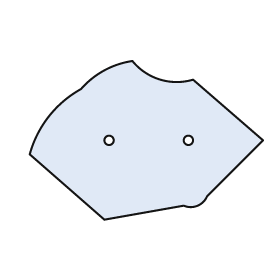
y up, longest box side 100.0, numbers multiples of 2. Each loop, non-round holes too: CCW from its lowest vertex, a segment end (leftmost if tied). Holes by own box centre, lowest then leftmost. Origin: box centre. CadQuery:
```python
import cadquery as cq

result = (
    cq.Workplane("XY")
    .moveTo(-18.0, -34.0)
    .lineTo(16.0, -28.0)
    .threePointArc((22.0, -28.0), (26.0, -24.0))
    .lineTo(50.0, 0.0)
    .lineTo(20.0, 26.0)
    .threePointArc((6.0, 26.0), (-6.0, 34.0))
    .threePointArc((-18.0, 30.0), (-28.0, 22.0))
    .threePointArc((-42.0, 10.0), (-50.0, -6.0))
    .close()
    .moveTo(-16.0, 0.0)
    .circle(2.0)
    .moveTo(18.0, 0.0)
    .circle(2.0)
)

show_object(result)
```